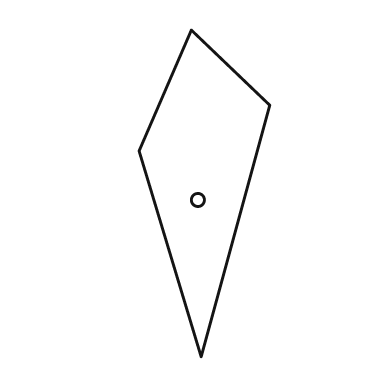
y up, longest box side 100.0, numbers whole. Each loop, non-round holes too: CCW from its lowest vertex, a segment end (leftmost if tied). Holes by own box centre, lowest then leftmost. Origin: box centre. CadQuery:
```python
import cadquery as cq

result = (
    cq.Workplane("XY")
    .moveTo(-1.0, -50.0)
    .lineTo(20.0, 27.0)
    .lineTo(-4.0, 50.0)
    .lineTo(-20.0, 13.0)
    .close()
    .moveTo(-2.0, -2.0)
    .circle(2.0)
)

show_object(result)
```